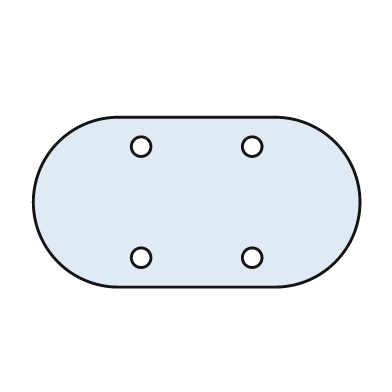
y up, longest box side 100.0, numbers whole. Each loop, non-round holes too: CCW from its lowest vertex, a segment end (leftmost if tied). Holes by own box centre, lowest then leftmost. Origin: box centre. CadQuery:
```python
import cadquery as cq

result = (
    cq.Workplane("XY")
    .moveTo(-24.0, -26.0)
    .lineTo(24.0, -26.0)
    .threePointArc((50.0, 0.0), (24.0, 26.0))
    .lineTo(-24.0, 26.0)
    .threePointArc((-50.0, 0.0), (-24.0, -26.0))
    .close()
    .moveTo(-17.0, -17.0)
    .circle(3.0)
    .moveTo(17.0, -17.0)
    .circle(3.0)
    .moveTo(-17.0, 17.0)
    .circle(3.0)
    .moveTo(17.0, 17.0)
    .circle(3.0)
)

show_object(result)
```